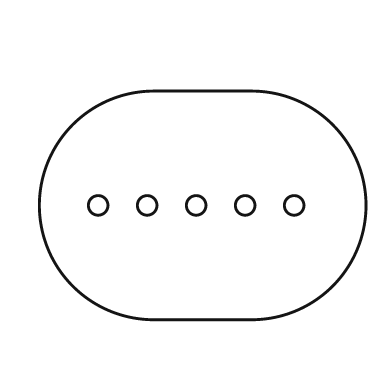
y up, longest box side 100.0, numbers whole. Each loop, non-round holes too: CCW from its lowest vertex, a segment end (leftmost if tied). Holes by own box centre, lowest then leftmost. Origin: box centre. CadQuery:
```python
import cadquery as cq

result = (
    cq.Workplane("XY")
    .moveTo(-15.0, -35.0)
    .lineTo(15.0, -35.0)
    .threePointArc((50.0, 0.0), (15.0, 35.0))
    .lineTo(-15.0, 35.0)
    .threePointArc((-50.0, 0.0), (-15.0, -35.0))
    .close()
    .moveTo(-32.0, 0.0)
    .circle(3.0)
    .moveTo(-17.0, 0.0)
    .circle(3.0)
    .moveTo(-2.0, 0.0)
    .circle(3.0)
    .moveTo(13.0, 0.0)
    .circle(3.0)
    .moveTo(28.0, 0.0)
    .circle(3.0)
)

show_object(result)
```